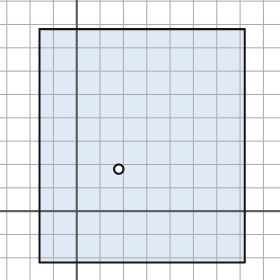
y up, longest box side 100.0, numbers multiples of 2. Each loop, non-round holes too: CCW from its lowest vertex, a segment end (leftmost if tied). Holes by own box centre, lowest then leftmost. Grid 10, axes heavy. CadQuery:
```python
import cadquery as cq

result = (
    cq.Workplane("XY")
    .moveTo(-16.0, -22.0)
    .lineTo(72.0, -22.0)
    .lineTo(72.0, 78.0)
    .lineTo(-16.0, 78.0)
    .close()
    .moveTo(18.0, 18.0)
    .circle(2.0)
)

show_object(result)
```